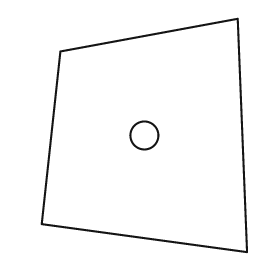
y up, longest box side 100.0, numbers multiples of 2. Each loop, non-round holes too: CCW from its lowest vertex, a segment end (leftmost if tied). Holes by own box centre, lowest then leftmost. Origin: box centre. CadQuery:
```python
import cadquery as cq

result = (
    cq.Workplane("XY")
    .moveTo(44.0, -50.0)
    .lineTo(40.0, 50.0)
    .lineTo(-36.0, 36.0)
    .lineTo(-44.0, -38.0)
    .close()
    .moveTo(0.0, 0.0)
    .circle(6.0)
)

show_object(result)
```